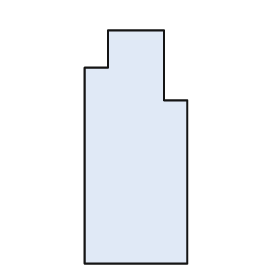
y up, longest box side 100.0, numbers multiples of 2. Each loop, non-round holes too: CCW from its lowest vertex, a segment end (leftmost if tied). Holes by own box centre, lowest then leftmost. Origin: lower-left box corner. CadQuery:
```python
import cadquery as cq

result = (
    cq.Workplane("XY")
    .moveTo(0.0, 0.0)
    .lineTo(44.0, 0.0)
    .lineTo(44.0, 70.0)
    .lineTo(34.0, 70.0)
    .lineTo(34.0, 100.0)
    .lineTo(10.0, 100.0)
    .lineTo(10.0, 84.0)
    .lineTo(0.0, 84.0)
    .close()
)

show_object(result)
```